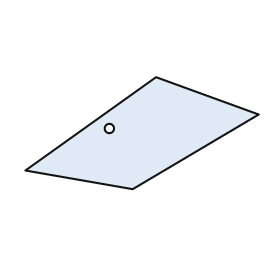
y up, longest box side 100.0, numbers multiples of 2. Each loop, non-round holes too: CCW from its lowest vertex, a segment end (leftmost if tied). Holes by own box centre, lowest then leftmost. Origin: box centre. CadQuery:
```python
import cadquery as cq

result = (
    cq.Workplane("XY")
    .moveTo(-4.0, -24.0)
    .lineTo(50.0, 8.0)
    .lineTo(6.0, 24.0)
    .lineTo(-50.0, -16.0)
    .close()
    .moveTo(-14.0, 2.0)
    .circle(2.0)
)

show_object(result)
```